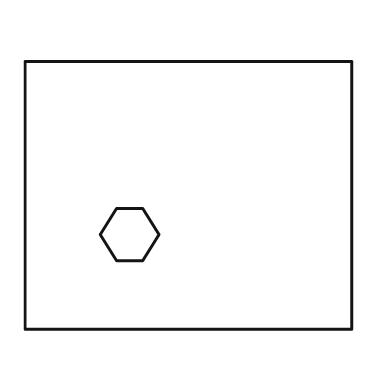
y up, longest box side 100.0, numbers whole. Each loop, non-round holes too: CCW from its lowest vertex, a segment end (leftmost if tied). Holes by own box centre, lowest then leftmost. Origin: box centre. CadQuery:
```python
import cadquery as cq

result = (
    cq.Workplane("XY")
    .moveTo(-50.0, -41.0)
    .lineTo(50.0, -41.0)
    .lineTo(50.0, 41.0)
    .lineTo(-50.0, 41.0)
    .close()
    .moveTo(-22.0, -20.0)
    .lineTo(-14.0, -20.0)
    .lineTo(-9.0, -12.0)
    .lineTo(-14.0, -4.0)
    .lineTo(-22.0, -4.0)
    .lineTo(-27.0, -12.0)
    .close()
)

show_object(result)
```